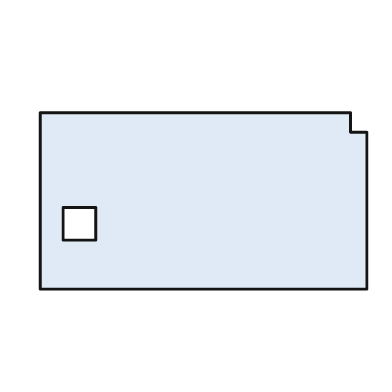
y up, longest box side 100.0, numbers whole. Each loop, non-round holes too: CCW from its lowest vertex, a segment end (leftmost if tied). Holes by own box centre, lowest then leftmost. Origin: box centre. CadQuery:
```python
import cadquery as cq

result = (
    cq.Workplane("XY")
    .moveTo(-50.0, -27.0)
    .lineTo(50.0, -27.0)
    .lineTo(50.0, 21.0)
    .lineTo(45.0, 21.0)
    .lineTo(45.0, 27.0)
    .lineTo(-50.0, 27.0)
    .close()
    .moveTo(-43.0, -12.0)
    .lineTo(-33.0, -12.0)
    .lineTo(-33.0, -2.0)
    .lineTo(-43.0, -2.0)
    .close()
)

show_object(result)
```